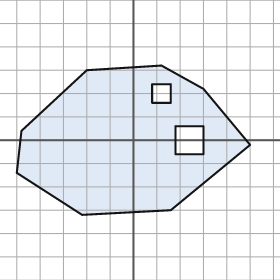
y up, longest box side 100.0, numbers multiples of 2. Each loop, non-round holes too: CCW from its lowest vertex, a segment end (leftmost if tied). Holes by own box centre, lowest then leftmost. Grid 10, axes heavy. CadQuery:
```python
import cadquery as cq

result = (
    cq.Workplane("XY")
    .moveTo(-22.0, -32.0)
    .lineTo(16.0, -30.0)
    .lineTo(50.0, -2.0)
    .lineTo(30.0, 22.0)
    .lineTo(12.0, 32.0)
    .lineTo(-20.0, 30.0)
    .lineTo(-48.0, 4.0)
    .lineTo(-50.0, -14.0)
    .close()
    .moveTo(18.0, -6.0)
    .lineTo(30.0, -6.0)
    .lineTo(30.0, 6.0)
    .lineTo(18.0, 6.0)
    .close()
    .moveTo(8.0, 16.0)
    .lineTo(16.0, 16.0)
    .lineTo(16.0, 24.0)
    .lineTo(8.0, 24.0)
    .close()
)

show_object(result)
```